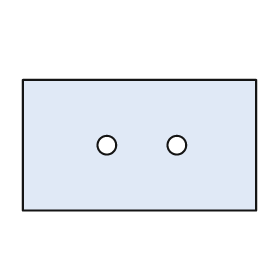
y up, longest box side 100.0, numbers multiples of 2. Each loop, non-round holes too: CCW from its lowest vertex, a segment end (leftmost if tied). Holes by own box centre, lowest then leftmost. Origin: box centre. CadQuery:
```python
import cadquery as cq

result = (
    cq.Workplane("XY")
    .moveTo(-50.0, -28.0)
    .lineTo(50.0, -28.0)
    .lineTo(50.0, 28.0)
    .lineTo(-50.0, 28.0)
    .close()
    .moveTo(-14.0, 0.0)
    .circle(4.0)
    .moveTo(16.0, 0.0)
    .circle(4.0)
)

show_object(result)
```